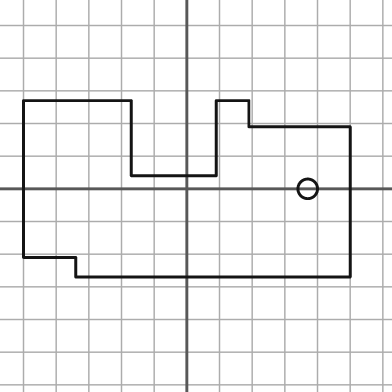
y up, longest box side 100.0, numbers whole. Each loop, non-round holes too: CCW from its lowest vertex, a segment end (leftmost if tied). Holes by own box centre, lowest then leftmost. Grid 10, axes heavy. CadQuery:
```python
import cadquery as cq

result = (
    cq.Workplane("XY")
    .moveTo(-34.0, -27.0)
    .lineTo(50.0, -27.0)
    .lineTo(50.0, 19.0)
    .lineTo(19.0, 19.0)
    .lineTo(19.0, 27.0)
    .lineTo(9.0, 27.0)
    .lineTo(9.0, 4.0)
    .lineTo(-17.0, 4.0)
    .lineTo(-17.0, 27.0)
    .lineTo(-50.0, 27.0)
    .lineTo(-50.0, -21.0)
    .lineTo(-34.0, -21.0)
    .close()
    .moveTo(37.0, 0.0)
    .circle(3.0)
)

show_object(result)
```